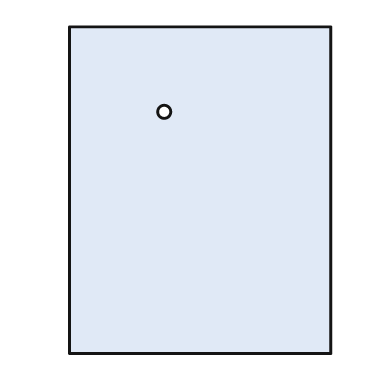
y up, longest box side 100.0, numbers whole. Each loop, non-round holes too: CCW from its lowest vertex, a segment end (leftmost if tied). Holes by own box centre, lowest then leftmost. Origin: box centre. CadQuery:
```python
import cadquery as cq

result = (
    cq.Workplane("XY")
    .moveTo(-40.0, -50.0)
    .lineTo(40.0, -50.0)
    .lineTo(40.0, 50.0)
    .lineTo(-40.0, 50.0)
    .close()
    .moveTo(-11.0, 24.0)
    .circle(2.0)
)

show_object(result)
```